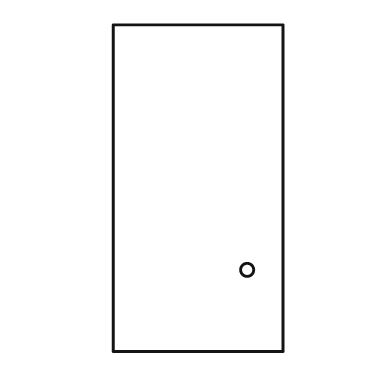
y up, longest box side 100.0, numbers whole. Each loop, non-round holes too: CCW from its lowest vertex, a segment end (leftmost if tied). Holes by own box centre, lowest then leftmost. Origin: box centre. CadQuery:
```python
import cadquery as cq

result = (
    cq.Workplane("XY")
    .moveTo(-26.0, -50.0)
    .lineTo(26.0, -50.0)
    .lineTo(26.0, 50.0)
    .lineTo(-26.0, 50.0)
    .close()
    .moveTo(15.0, -25.0)
    .circle(2.0)
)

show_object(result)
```